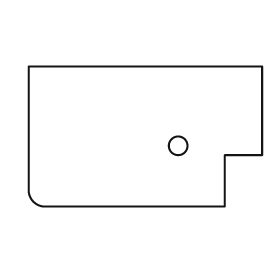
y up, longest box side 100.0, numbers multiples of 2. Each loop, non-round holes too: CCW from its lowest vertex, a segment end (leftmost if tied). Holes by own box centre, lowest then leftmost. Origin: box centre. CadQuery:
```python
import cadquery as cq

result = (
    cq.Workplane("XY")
    .moveTo(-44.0, -30.0)
    .lineTo(34.0, -30.0)
    .lineTo(34.0, -8.0)
    .lineTo(50.0, -8.0)
    .lineTo(50.0, 30.0)
    .lineTo(-50.0, 30.0)
    .lineTo(-50.0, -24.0)
    .threePointArc((-48.0, -28.0), (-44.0, -30.0))
    .close()
    .moveTo(14.0, -4.0)
    .circle(4.0)
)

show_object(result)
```